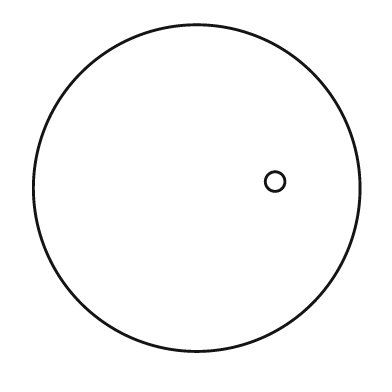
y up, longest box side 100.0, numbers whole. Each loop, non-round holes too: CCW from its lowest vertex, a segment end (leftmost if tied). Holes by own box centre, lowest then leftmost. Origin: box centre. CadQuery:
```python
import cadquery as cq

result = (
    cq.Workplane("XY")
    .moveTo(0.0, 0.0)
    .circle(50.0)
    .moveTo(24.0, 2.0)
    .circle(3.0)
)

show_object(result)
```